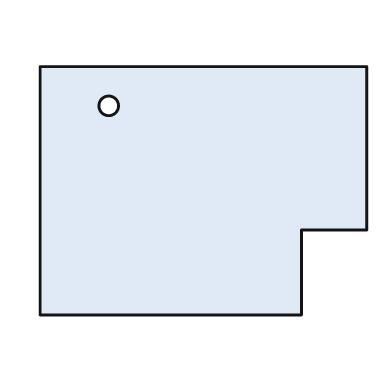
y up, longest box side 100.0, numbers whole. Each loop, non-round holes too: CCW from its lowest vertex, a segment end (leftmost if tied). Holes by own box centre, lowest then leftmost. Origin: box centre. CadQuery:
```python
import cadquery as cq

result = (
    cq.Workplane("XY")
    .moveTo(-50.0, -38.0)
    .lineTo(30.0, -38.0)
    .lineTo(30.0, -12.0)
    .lineTo(50.0, -12.0)
    .lineTo(50.0, 38.0)
    .lineTo(-50.0, 38.0)
    .close()
    .moveTo(-29.0, 26.0)
    .circle(3.0)
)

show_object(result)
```